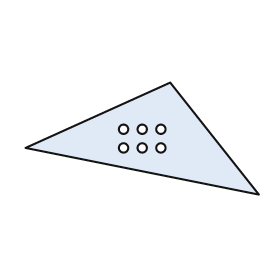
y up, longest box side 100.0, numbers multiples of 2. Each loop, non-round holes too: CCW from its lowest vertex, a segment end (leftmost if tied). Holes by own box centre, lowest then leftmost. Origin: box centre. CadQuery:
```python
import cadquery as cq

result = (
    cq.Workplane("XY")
    .moveTo(50.0, -24.0)
    .lineTo(12.0, 24.0)
    .lineTo(-50.0, -4.0)
    .close()
    .moveTo(-8.0, -4.0)
    .circle(2.0)
    .moveTo(0.0, -4.0)
    .circle(2.0)
    .moveTo(8.0, -4.0)
    .circle(2.0)
    .moveTo(-8.0, 4.0)
    .circle(2.0)
    .moveTo(0.0, 4.0)
    .circle(2.0)
    .moveTo(8.0, 4.0)
    .circle(2.0)
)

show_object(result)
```